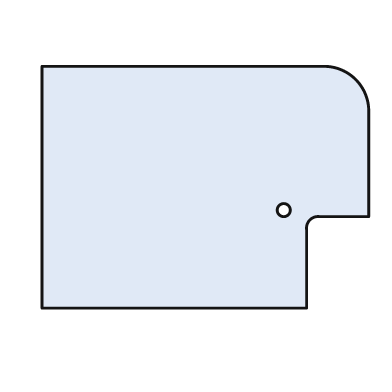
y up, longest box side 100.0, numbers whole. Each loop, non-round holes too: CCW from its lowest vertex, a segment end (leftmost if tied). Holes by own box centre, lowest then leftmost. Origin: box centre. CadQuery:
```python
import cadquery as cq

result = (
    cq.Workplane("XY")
    .moveTo(-50.0, -37.0)
    .lineTo(31.0, -37.0)
    .lineTo(31.0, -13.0)
    .threePointArc((32.0, -10.0), (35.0, -9.0))
    .lineTo(50.0, -9.0)
    .lineTo(50.0, 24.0)
    .threePointArc((46.0, 33.0), (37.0, 37.0))
    .lineTo(-50.0, 37.0)
    .close()
    .moveTo(24.0, -7.0)
    .circle(2.0)
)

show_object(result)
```